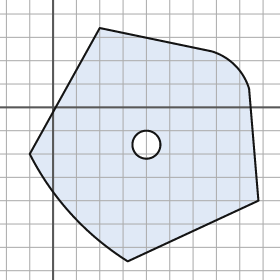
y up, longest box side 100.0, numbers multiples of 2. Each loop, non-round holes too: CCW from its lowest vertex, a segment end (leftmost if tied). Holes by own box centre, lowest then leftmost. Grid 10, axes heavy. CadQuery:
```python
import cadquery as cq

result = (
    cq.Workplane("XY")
    .moveTo(32.0, -66.0)
    .lineTo(88.0, -40.0)
    .lineTo(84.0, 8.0)
    .threePointArc((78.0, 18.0), (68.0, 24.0))
    .lineTo(20.0, 34.0)
    .lineTo(-10.0, -20.0)
    .threePointArc((8.0, -46.0), (32.0, -66.0))
    .close()
    .moveTo(40.0, -16.0)
    .circle(6.0)
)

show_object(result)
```